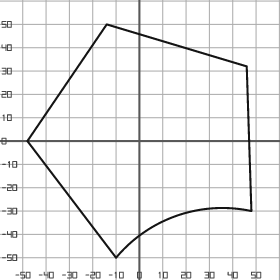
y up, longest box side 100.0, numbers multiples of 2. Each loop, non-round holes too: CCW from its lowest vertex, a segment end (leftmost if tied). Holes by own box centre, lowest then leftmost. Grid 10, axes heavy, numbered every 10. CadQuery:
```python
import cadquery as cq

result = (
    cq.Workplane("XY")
    .moveTo(-10.0, -50.0)
    .threePointArc((16.0, -32.0), (48.0, -30.0))
    .lineTo(46.0, 32.0)
    .lineTo(-14.0, 50.0)
    .lineTo(-48.0, 0.0)
    .close()
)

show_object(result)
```